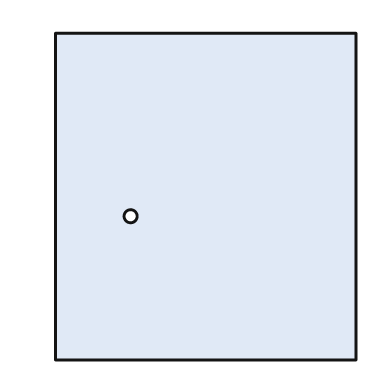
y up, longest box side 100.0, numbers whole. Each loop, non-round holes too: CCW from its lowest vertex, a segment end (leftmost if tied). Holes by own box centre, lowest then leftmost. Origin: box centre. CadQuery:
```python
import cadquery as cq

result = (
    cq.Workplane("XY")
    .moveTo(-46.0, -50.0)
    .lineTo(46.0, -50.0)
    .lineTo(46.0, 50.0)
    .lineTo(-46.0, 50.0)
    .close()
    .moveTo(-23.0, -6.0)
    .circle(2.0)
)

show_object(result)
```